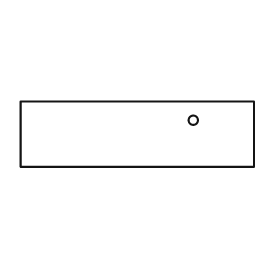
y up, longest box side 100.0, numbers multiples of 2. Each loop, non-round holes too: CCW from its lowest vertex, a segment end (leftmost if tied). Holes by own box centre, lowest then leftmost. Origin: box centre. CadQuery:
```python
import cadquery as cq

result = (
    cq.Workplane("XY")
    .moveTo(-50.0, -14.0)
    .lineTo(50.0, -14.0)
    .lineTo(50.0, 14.0)
    .lineTo(-50.0, 14.0)
    .close()
    .moveTo(24.0, 6.0)
    .circle(2.0)
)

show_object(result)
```